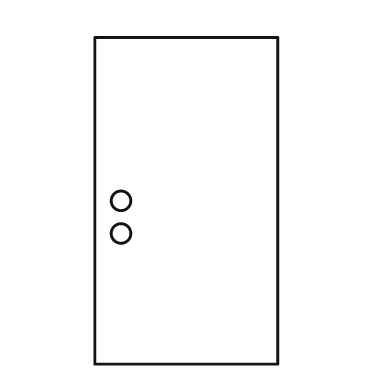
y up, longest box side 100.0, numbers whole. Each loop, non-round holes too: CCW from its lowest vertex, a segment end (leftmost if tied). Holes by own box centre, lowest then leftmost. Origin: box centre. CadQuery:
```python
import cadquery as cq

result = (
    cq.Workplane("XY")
    .moveTo(-28.0, -50.0)
    .lineTo(28.0, -50.0)
    .lineTo(28.0, 50.0)
    .lineTo(-28.0, 50.0)
    .close()
    .moveTo(-20.0, -10.0)
    .circle(3.0)
    .moveTo(-20.0, 0.0)
    .circle(3.0)
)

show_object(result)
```